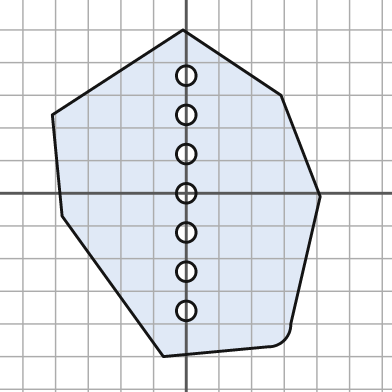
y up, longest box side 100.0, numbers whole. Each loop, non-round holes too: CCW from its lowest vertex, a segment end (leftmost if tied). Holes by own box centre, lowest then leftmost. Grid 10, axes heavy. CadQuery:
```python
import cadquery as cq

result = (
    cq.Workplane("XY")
    .moveTo(-7.0, -50.0)
    .lineTo(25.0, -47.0)
    .threePointArc((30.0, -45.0), (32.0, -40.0))
    .lineTo(41.0, -1.0)
    .lineTo(29.0, 30.0)
    .lineTo(-1.0, 50.0)
    .lineTo(-41.0, 24.0)
    .lineTo(-38.0, -7.0)
    .close()
    .moveTo(0.0, -36.0)
    .circle(3.0)
    .moveTo(0.0, -24.0)
    .circle(3.0)
    .moveTo(0.0, -12.0)
    .circle(3.0)
    .moveTo(0.0, 0.0)
    .circle(3.0)
    .moveTo(0.0, 12.0)
    .circle(3.0)
    .moveTo(0.0, 24.0)
    .circle(3.0)
    .moveTo(0.0, 36.0)
    .circle(3.0)
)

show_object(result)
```